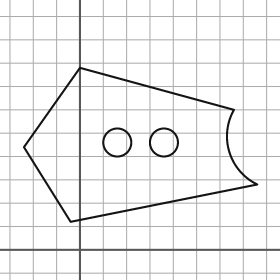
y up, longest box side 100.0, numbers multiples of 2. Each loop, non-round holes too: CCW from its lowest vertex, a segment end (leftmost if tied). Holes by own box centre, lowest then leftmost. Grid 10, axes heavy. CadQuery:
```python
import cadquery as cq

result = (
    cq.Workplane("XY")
    .moveTo(-4.0, 12.0)
    .lineTo(76.0, 28.0)
    .threePointArc((64.0, 42.0), (66.0, 60.0))
    .lineTo(0.0, 78.0)
    .lineTo(-24.0, 44.0)
    .close()
    .moveTo(16.0, 46.0)
    .circle(6.0)
    .moveTo(36.0, 46.0)
    .circle(6.0)
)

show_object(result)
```